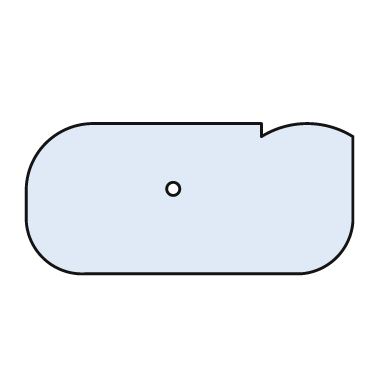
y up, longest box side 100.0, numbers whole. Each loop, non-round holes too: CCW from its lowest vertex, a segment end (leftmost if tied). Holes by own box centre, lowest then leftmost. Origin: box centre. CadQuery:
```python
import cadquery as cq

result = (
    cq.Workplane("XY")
    .moveTo(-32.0, -23.0)
    .lineTo(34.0, -23.0)
    .threePointArc((45.0, -18.0), (50.0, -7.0))
    .lineTo(50.0, 19.0)
    .threePointArc((36.0, 23.0), (22.0, 19.0))
    .lineTo(22.0, 23.0)
    .lineTo(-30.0, 23.0)
    .threePointArc((-44.0, 17.0), (-50.0, 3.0))
    .lineTo(-50.0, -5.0)
    .threePointArc((-45.0, -18.0), (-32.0, -23.0))
    .close()
    .moveTo(-5.0, 3.0)
    .circle(2.0)
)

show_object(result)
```